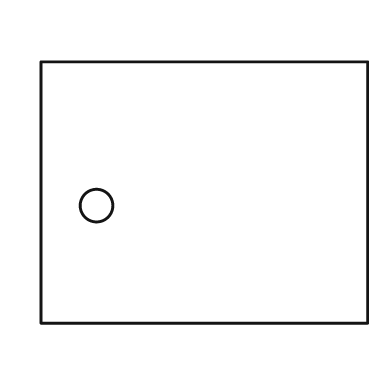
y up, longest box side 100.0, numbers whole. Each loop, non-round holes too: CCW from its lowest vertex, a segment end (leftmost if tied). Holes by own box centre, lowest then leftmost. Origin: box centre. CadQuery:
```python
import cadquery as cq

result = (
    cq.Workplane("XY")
    .moveTo(-50.0, -40.0)
    .lineTo(50.0, -40.0)
    .lineTo(50.0, 40.0)
    .lineTo(-50.0, 40.0)
    .close()
    .moveTo(-33.0, -4.0)
    .circle(5.0)
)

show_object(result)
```